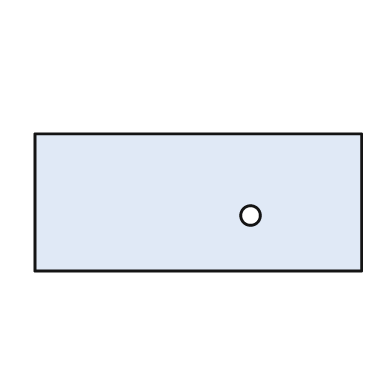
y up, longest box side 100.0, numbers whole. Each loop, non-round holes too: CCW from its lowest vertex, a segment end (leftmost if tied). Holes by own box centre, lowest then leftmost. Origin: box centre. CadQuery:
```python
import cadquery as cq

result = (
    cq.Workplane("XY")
    .moveTo(-50.0, -21.0)
    .lineTo(50.0, -21.0)
    .lineTo(50.0, 21.0)
    .lineTo(-50.0, 21.0)
    .close()
    .moveTo(16.0, -4.0)
    .circle(3.0)
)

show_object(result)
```